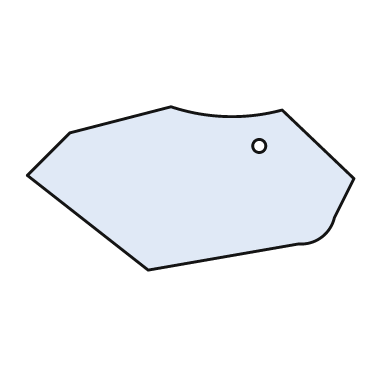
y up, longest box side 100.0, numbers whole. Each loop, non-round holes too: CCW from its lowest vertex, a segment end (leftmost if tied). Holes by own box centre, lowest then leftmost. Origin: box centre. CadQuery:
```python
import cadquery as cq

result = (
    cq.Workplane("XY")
    .moveTo(-13.0, -25.0)
    .lineTo(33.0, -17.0)
    .threePointArc((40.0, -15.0), (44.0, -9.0))
    .lineTo(50.0, 3.0)
    .lineTo(28.0, 24.0)
    .threePointArc((11.0, 22.0), (-6.0, 25.0))
    .lineTo(-37.0, 17.0)
    .lineTo(-50.0, 4.0)
    .close()
    .moveTo(21.0, 13.0)
    .circle(2.0)
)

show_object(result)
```